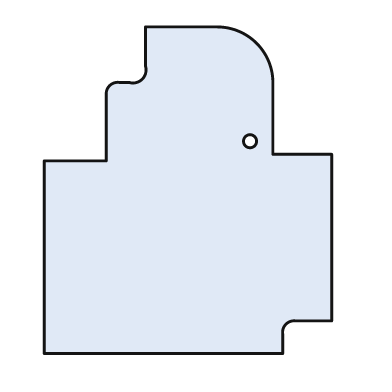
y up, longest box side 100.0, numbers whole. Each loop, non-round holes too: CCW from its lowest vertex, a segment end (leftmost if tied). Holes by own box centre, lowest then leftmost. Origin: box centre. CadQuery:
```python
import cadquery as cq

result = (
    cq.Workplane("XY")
    .moveTo(-44.0, -50.0)
    .lineTo(29.0, -50.0)
    .lineTo(29.0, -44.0)
    .threePointArc((30.0, -41.0), (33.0, -40.0))
    .lineTo(44.0, -40.0)
    .lineTo(44.0, 11.0)
    .lineTo(26.0, 11.0)
    .lineTo(26.0, 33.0)
    .threePointArc((21.0, 45.0), (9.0, 50.0))
    .lineTo(-13.0, 50.0)
    .lineTo(-13.0, 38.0)
    .threePointArc((-14.0, 34.0), (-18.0, 33.0))
    .lineTo(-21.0, 33.0)
    .threePointArc((-24.0, 32.0), (-25.0, 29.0))
    .lineTo(-25.0, 9.0)
    .lineTo(-44.0, 9.0)
    .close()
    .moveTo(19.0, 15.0)
    .circle(2.0)
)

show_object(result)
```